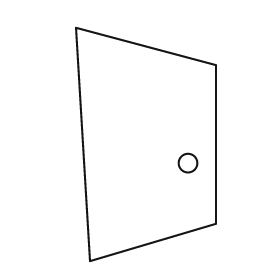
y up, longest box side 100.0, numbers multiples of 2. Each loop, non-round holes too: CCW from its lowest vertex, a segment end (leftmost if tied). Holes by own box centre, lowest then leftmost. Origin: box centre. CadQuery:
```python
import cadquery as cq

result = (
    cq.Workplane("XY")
    .moveTo(-24.0, -50.0)
    .lineTo(30.0, -34.0)
    .lineTo(30.0, 34.0)
    .lineTo(-30.0, 50.0)
    .close()
    .moveTo(18.0, -8.0)
    .circle(4.0)
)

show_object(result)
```